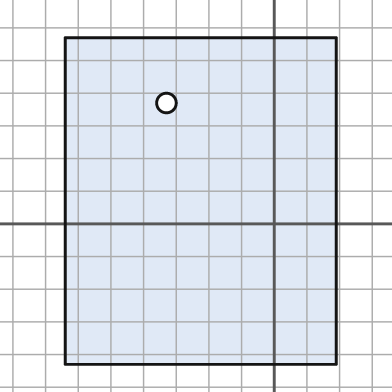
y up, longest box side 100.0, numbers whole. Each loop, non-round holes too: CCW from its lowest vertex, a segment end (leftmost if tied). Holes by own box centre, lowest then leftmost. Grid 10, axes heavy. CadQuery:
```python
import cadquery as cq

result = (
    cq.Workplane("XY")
    .moveTo(-64.0, -43.0)
    .lineTo(19.0, -43.0)
    .lineTo(19.0, 57.0)
    .lineTo(-64.0, 57.0)
    .close()
    .moveTo(-33.0, 37.0)
    .circle(3.0)
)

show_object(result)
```